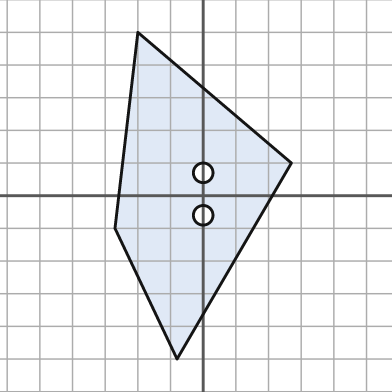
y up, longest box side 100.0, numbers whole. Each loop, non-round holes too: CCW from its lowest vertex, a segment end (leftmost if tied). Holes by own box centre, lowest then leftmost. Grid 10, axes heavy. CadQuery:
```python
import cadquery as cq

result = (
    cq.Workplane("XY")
    .moveTo(-8.0, -50.0)
    .lineTo(27.0, 10.0)
    .lineTo(-20.0, 50.0)
    .lineTo(-27.0, -10.0)
    .close()
    .moveTo(0.0, -6.0)
    .circle(3.0)
    .moveTo(0.0, 7.0)
    .circle(3.0)
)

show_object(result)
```